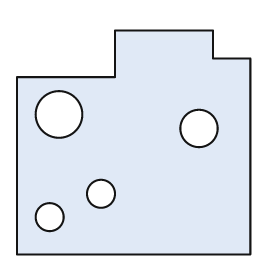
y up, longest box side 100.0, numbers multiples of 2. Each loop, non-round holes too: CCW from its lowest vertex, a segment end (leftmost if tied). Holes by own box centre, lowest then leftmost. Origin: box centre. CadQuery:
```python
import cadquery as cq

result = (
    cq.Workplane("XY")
    .moveTo(-50.0, -48.0)
    .lineTo(50.0, -48.0)
    .lineTo(50.0, 36.0)
    .lineTo(34.0, 36.0)
    .lineTo(34.0, 48.0)
    .lineTo(-8.0, 48.0)
    .lineTo(-8.0, 28.0)
    .lineTo(-50.0, 28.0)
    .close()
    .moveTo(-36.0, -32.0)
    .circle(6.0)
    .moveTo(-14.0, -22.0)
    .circle(6.0)
    .moveTo(28.0, 6.0)
    .circle(8.0)
    .moveTo(-32.0, 12.0)
    .circle(10.0)
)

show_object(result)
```